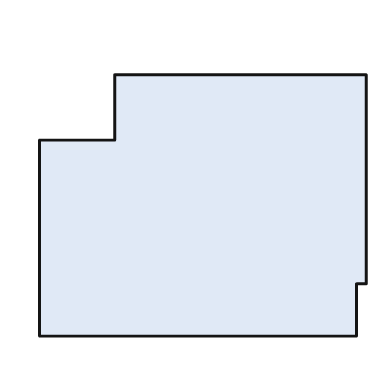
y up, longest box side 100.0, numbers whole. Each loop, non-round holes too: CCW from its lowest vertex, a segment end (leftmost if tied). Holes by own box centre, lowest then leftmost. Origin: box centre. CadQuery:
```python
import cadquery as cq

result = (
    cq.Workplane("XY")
    .moveTo(-50.0, -40.0)
    .lineTo(47.0, -40.0)
    .lineTo(47.0, -24.0)
    .lineTo(50.0, -24.0)
    .lineTo(50.0, 40.0)
    .lineTo(-27.0, 40.0)
    .lineTo(-27.0, 20.0)
    .lineTo(-50.0, 20.0)
    .close()
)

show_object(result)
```